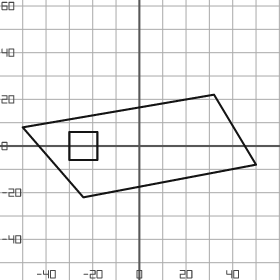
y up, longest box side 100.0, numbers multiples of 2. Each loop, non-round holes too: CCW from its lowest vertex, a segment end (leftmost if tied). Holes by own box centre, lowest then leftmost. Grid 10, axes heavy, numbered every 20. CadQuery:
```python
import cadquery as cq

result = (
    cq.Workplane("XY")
    .moveTo(-24.0, -22.0)
    .lineTo(50.0, -8.0)
    .lineTo(32.0, 22.0)
    .lineTo(-50.0, 8.0)
    .close()
    .moveTo(-30.0, -6.0)
    .lineTo(-18.0, -6.0)
    .lineTo(-18.0, 6.0)
    .lineTo(-30.0, 6.0)
    .close()
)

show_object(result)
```